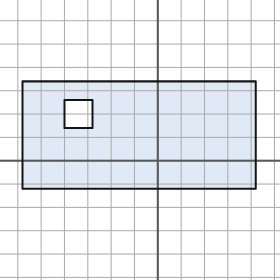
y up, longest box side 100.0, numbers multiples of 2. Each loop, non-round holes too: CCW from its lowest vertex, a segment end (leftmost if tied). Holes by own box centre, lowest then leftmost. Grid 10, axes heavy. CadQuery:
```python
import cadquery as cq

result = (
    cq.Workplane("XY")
    .moveTo(-58.0, -12.0)
    .lineTo(42.0, -12.0)
    .lineTo(42.0, 34.0)
    .lineTo(-58.0, 34.0)
    .close()
    .moveTo(-40.0, 14.0)
    .lineTo(-28.0, 14.0)
    .lineTo(-28.0, 26.0)
    .lineTo(-40.0, 26.0)
    .close()
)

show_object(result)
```